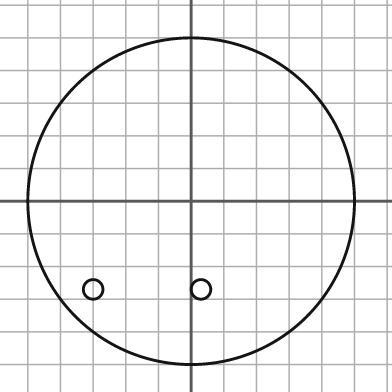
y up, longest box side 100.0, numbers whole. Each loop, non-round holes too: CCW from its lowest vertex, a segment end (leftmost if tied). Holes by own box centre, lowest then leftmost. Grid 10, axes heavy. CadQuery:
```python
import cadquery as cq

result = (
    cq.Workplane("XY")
    .moveTo(0.0, 0.0)
    .circle(50.0)
    .moveTo(-30.0, -27.0)
    .circle(3.0)
    .moveTo(3.0, -27.0)
    .circle(3.0)
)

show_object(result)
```